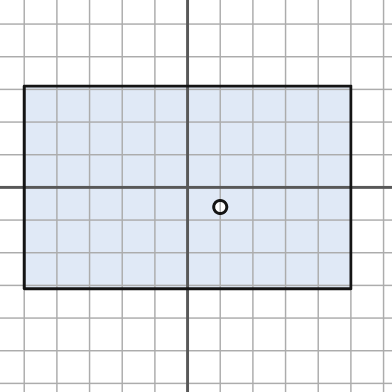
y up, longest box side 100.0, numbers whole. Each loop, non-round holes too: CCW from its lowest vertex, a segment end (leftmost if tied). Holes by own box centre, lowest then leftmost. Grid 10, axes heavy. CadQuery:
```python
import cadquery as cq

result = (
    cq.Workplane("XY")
    .moveTo(-50.0, -31.0)
    .lineTo(50.0, -31.0)
    .lineTo(50.0, 31.0)
    .lineTo(-50.0, 31.0)
    .close()
    .moveTo(10.0, -6.0)
    .circle(2.0)
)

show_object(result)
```